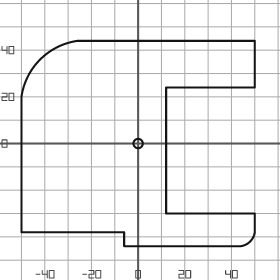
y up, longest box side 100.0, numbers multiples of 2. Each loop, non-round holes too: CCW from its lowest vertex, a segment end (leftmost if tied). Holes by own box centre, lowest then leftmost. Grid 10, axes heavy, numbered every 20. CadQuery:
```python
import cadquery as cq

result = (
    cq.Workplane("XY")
    .moveTo(-6.0, -44.0)
    .lineTo(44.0, -44.0)
    .threePointArc((48.0, -42.0), (50.0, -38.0))
    .lineTo(50.0, -30.0)
    .lineTo(12.0, -30.0)
    .lineTo(12.0, 24.0)
    .lineTo(50.0, 24.0)
    .lineTo(50.0, 44.0)
    .lineTo(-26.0, 44.0)
    .threePointArc((-42.0, 36.0), (-50.0, 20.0))
    .lineTo(-50.0, -38.0)
    .lineTo(-6.0, -38.0)
    .close()
    .moveTo(0.0, 0.0)
    .circle(2.0)
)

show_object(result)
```